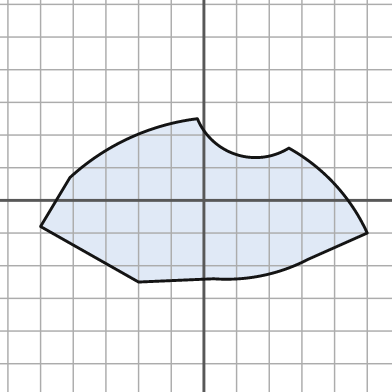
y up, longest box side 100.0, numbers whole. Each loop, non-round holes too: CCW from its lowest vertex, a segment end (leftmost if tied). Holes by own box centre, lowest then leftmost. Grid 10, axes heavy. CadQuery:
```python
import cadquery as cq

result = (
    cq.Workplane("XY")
    .moveTo(-20.0, -25.0)
    .lineTo(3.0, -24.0)
    .threePointArc((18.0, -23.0), (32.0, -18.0))
    .lineTo(50.0, -10.0)
    .threePointArc((40.0, 5.0), (26.0, 16.0))
    .threePointArc((10.0, 14.0), (-2.0, 25.0))
    .threePointArc((-23.0, 19.0), (-41.0, 7.0))
    .lineTo(-50.0, -8.0)
    .close()
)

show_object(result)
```